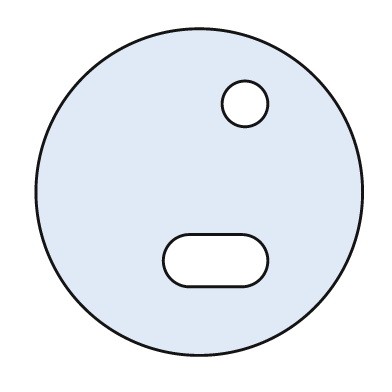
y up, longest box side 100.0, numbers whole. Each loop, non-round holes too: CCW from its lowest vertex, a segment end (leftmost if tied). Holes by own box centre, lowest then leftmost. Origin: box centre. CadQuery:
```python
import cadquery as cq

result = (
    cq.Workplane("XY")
    .moveTo(0.0, 0.0)
    .circle(50.0)
    .moveTo(-3.0, -29.0)
    .lineTo(13.0, -29.0)
    .threePointArc((21.0, -21.0), (13.0, -13.0))
    .lineTo(-3.0, -13.0)
    .threePointArc((-11.0, -21.0), (-3.0, -29.0))
    .close()
    .moveTo(14.0, 27.0)
    .circle(7.0)
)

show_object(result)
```